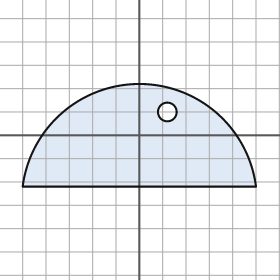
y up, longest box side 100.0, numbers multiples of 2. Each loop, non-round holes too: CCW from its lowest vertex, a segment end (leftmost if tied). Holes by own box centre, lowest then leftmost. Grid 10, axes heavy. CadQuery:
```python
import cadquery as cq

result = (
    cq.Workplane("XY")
    .moveTo(-50.0, -22.0)
    .lineTo(50.0, -22.0)
    .threePointArc((0.0, 22.0), (-50.0, -22.0))
    .close()
    .moveTo(12.0, 10.0)
    .circle(4.0)
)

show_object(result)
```